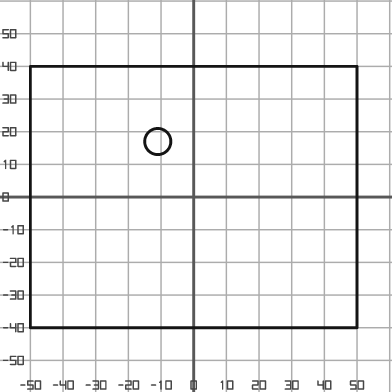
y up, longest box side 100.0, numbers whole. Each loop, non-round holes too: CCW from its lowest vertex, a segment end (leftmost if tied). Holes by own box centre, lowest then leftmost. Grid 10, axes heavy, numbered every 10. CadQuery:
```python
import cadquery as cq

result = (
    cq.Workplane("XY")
    .moveTo(-50.0, -40.0)
    .lineTo(50.0, -40.0)
    .lineTo(50.0, 40.0)
    .lineTo(-50.0, 40.0)
    .close()
    .moveTo(-11.0, 17.0)
    .circle(4.0)
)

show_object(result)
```